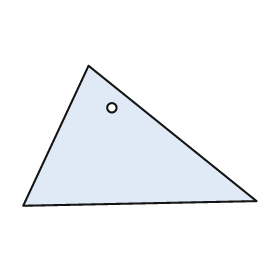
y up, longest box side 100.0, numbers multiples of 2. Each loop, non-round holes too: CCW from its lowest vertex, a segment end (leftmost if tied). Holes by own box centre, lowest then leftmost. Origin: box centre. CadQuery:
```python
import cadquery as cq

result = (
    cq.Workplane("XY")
    .moveTo(-50.0, -30.0)
    .lineTo(50.0, -28.0)
    .lineTo(-22.0, 30.0)
    .close()
    .moveTo(-12.0, 12.0)
    .circle(2.0)
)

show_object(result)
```